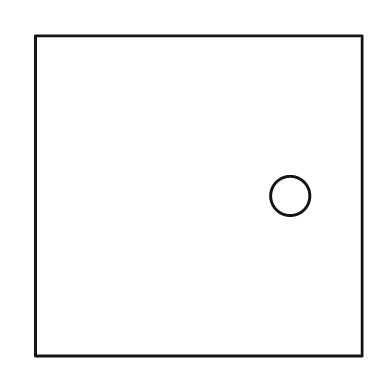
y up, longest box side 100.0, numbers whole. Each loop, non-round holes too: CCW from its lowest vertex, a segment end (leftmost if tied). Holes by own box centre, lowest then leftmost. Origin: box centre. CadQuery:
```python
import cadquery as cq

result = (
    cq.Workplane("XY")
    .moveTo(-50.0, -49.0)
    .lineTo(50.0, -49.0)
    .lineTo(50.0, 49.0)
    .lineTo(-50.0, 49.0)
    .close()
    .moveTo(28.0, 0.0)
    .circle(6.0)
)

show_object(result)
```